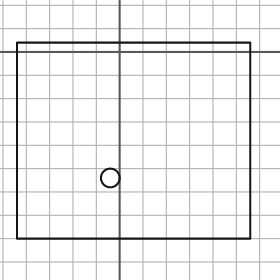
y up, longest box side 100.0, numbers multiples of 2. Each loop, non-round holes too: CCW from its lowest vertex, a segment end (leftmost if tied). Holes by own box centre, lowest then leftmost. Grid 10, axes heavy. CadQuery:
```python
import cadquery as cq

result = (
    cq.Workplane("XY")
    .moveTo(-44.0, -80.0)
    .lineTo(56.0, -80.0)
    .lineTo(56.0, 4.0)
    .lineTo(-44.0, 4.0)
    .close()
    .moveTo(-4.0, -54.0)
    .circle(4.0)
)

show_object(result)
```